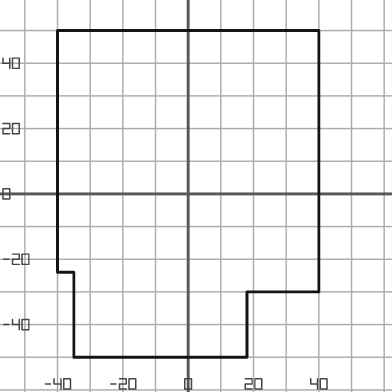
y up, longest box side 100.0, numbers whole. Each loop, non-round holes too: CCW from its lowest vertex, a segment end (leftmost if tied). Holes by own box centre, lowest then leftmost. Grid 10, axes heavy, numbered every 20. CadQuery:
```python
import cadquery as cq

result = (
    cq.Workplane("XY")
    .moveTo(-35.0, -50.0)
    .lineTo(18.0, -50.0)
    .lineTo(18.0, -30.0)
    .lineTo(40.0, -30.0)
    .lineTo(40.0, 50.0)
    .lineTo(-40.0, 50.0)
    .lineTo(-40.0, -24.0)
    .lineTo(-35.0, -24.0)
    .close()
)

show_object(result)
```